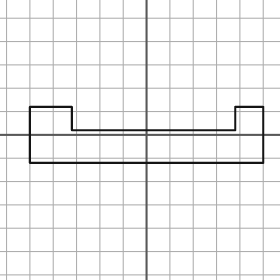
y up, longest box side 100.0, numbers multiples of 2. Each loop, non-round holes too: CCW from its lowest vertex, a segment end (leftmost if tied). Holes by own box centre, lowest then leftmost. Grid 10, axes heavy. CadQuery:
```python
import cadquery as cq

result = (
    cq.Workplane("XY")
    .moveTo(-50.0, -12.0)
    .lineTo(50.0, -12.0)
    .lineTo(50.0, 12.0)
    .lineTo(38.0, 12.0)
    .lineTo(38.0, 2.0)
    .lineTo(-32.0, 2.0)
    .lineTo(-32.0, 12.0)
    .lineTo(-50.0, 12.0)
    .close()
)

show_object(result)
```